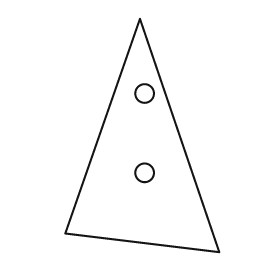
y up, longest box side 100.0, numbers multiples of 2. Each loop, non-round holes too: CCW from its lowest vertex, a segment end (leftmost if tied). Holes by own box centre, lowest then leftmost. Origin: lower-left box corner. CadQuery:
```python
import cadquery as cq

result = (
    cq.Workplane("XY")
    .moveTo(66.0, 0.0)
    .lineTo(32.0, 100.0)
    .lineTo(0.0, 8.0)
    .close()
    .moveTo(34.0, 34.0)
    .circle(4.0)
    .moveTo(34.0, 68.0)
    .circle(4.0)
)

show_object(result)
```